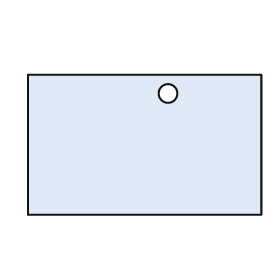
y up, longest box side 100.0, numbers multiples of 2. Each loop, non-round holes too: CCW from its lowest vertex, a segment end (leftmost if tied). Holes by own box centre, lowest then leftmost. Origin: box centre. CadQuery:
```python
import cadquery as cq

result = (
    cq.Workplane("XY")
    .moveTo(-50.0, -30.0)
    .lineTo(50.0, -30.0)
    .lineTo(50.0, 30.0)
    .lineTo(-50.0, 30.0)
    .close()
    .moveTo(10.0, 22.0)
    .circle(4.0)
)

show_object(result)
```